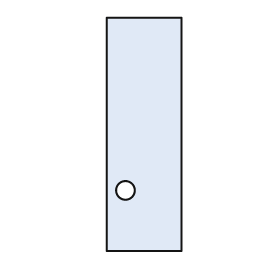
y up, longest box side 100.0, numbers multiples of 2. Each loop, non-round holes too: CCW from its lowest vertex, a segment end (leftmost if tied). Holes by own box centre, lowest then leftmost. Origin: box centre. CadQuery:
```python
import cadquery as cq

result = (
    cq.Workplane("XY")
    .moveTo(-16.0, -50.0)
    .lineTo(16.0, -50.0)
    .lineTo(16.0, 50.0)
    .lineTo(-16.0, 50.0)
    .close()
    .moveTo(-8.0, -24.0)
    .circle(4.0)
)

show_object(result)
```